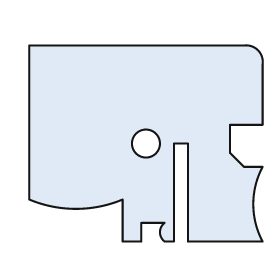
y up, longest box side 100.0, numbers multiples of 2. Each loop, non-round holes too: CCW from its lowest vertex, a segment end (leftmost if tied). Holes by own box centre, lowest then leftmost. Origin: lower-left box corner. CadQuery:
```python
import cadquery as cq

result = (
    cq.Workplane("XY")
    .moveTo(40.0, 0.0)
    .lineTo(48.0, 0.0)
    .lineTo(48.0, 8.0)
    .lineTo(58.0, 8.0)
    .threePointArc((56.0, 4.0), (58.0, 0.0))
    .lineTo(62.0, 0.0)
    .lineTo(62.0, 42.0)
    .lineTo(68.0, 42.0)
    .lineTo(68.0, 0.0)
    .lineTo(100.0, 0.0)
    .threePointArc((96.0, 16.0), (100.0, 32.0))
    .lineTo(92.0, 32.0)
    .lineTo(86.0, 38.0)
    .lineTo(86.0, 50.0)
    .lineTo(100.0, 50.0)
    .lineTo(100.0, 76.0)
    .threePointArc((98.0, 82.0), (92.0, 84.0))
    .lineTo(0.0, 84.0)
    .lineTo(0.0, 18.0)
    .threePointArc((20.0, 14.0), (40.0, 18.0))
    .close()
    .moveTo(50.0, 42.0)
    .circle(6.0)
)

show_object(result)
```